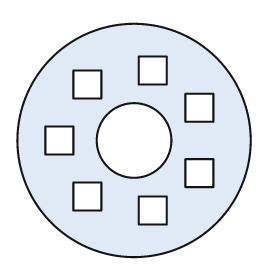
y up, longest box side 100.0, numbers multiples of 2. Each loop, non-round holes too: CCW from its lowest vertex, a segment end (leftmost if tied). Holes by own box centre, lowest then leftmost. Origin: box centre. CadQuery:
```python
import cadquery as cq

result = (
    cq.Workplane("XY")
    .moveTo(0.0, 0.0)
    .circle(50.0)
    .moveTo(2.0, -36.0)
    .lineTo(14.0, -36.0)
    .lineTo(14.0, -24.0)
    .lineTo(2.0, -24.0)
    .close()
    .moveTo(-26.0, -30.0)
    .lineTo(-14.0, -30.0)
    .lineTo(-14.0, -18.0)
    .lineTo(-26.0, -18.0)
    .close()
    .moveTo(22.0, -20.0)
    .lineTo(34.0, -20.0)
    .lineTo(34.0, -8.0)
    .lineTo(22.0, -8.0)
    .close()
    .moveTo(-38.0, -6.0)
    .lineTo(-26.0, -6.0)
    .lineTo(-26.0, 6.0)
    .lineTo(-38.0, 6.0)
    .close()
    .moveTo(0.0, 0.0)
    .circle(16.0)
    .moveTo(22.0, 8.0)
    .lineTo(34.0, 8.0)
    .lineTo(34.0, 20.0)
    .lineTo(22.0, 20.0)
    .close()
    .moveTo(-26.0, 18.0)
    .lineTo(-14.0, 18.0)
    .lineTo(-14.0, 30.0)
    .lineTo(-26.0, 30.0)
    .close()
    .moveTo(2.0, 24.0)
    .lineTo(14.0, 24.0)
    .lineTo(14.0, 36.0)
    .lineTo(2.0, 36.0)
    .close()
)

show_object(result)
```